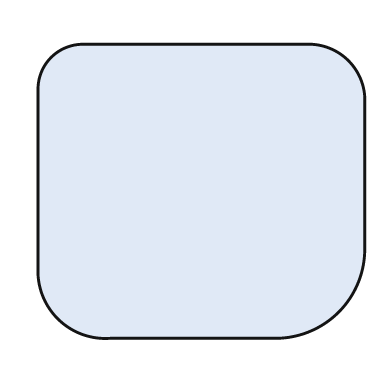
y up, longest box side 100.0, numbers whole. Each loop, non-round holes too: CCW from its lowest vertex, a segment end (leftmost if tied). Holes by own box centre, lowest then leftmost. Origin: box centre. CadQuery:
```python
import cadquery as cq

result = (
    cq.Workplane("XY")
    .moveTo(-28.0, -45.0)
    .lineTo(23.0, -45.0)
    .threePointArc((42.0, -37.0), (50.0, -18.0))
    .lineTo(50.0, 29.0)
    .threePointArc((45.0, 40.0), (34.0, 45.0))
    .lineTo(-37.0, 45.0)
    .threePointArc((-46.0, 41.0), (-50.0, 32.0))
    .lineTo(-50.0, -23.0)
    .threePointArc((-44.0, -39.0), (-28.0, -45.0))
    .close()
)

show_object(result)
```